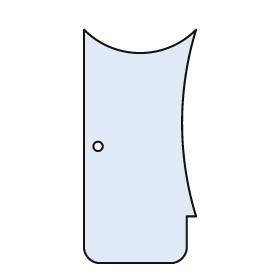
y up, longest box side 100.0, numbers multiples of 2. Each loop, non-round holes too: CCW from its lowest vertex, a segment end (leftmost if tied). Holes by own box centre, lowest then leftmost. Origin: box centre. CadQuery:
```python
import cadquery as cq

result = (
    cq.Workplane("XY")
    .moveTo(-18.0, -50.0)
    .lineTo(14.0, -50.0)
    .threePointArc((18.0, -48.0), (20.0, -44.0))
    .lineTo(20.0, -30.0)
    .lineTo(24.0, -30.0)
    .threePointArc((18.0, 10.0), (24.0, 50.0))
    .threePointArc((0.0, 40.0), (-24.0, 50.0))
    .lineTo(-24.0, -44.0)
    .threePointArc((-22.0, -48.0), (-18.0, -50.0))
    .close()
    .moveTo(-18.0, 0.0)
    .circle(2.0)
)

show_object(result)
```